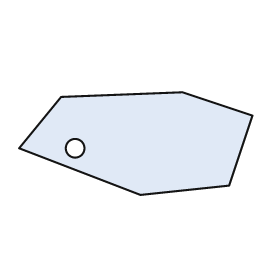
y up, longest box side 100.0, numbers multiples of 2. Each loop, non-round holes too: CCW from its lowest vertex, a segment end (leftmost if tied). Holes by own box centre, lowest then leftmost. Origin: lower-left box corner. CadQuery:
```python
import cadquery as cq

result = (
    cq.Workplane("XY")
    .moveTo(52.0, 0.0)
    .lineTo(90.0, 4.0)
    .lineTo(100.0, 34.0)
    .lineTo(70.0, 44.0)
    .lineTo(18.0, 42.0)
    .lineTo(0.0, 20.0)
    .close()
    .moveTo(24.0, 20.0)
    .circle(4.0)
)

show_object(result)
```